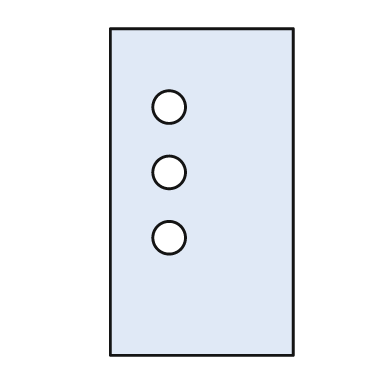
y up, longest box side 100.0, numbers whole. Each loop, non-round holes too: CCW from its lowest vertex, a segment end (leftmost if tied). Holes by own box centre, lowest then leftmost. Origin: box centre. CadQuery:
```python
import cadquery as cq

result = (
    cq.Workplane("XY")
    .moveTo(-28.0, -50.0)
    .lineTo(28.0, -50.0)
    .lineTo(28.0, 50.0)
    .lineTo(-28.0, 50.0)
    .close()
    .moveTo(-10.0, -14.0)
    .circle(5.0)
    .moveTo(-10.0, 6.0)
    .circle(5.0)
    .moveTo(-10.0, 26.0)
    .circle(5.0)
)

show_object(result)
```